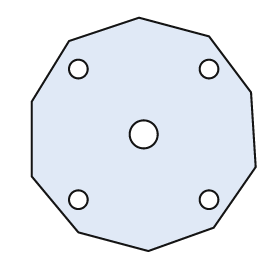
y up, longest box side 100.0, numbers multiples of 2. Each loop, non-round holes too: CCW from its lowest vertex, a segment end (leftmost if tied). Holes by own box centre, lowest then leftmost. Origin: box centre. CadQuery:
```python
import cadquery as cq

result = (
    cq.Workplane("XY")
    .moveTo(2.0, -50.0)
    .lineTo(30.0, -40.0)
    .lineTo(48.0, -14.0)
    .lineTo(46.0, 18.0)
    .lineTo(28.0, 42.0)
    .lineTo(-2.0, 50.0)
    .lineTo(-32.0, 40.0)
    .lineTo(-48.0, 14.0)
    .lineTo(-48.0, -18.0)
    .lineTo(-28.0, -42.0)
    .close()
    .moveTo(-28.0, -28.0)
    .circle(4.0)
    .moveTo(28.0, -28.0)
    .circle(4.0)
    .moveTo(0.0, 0.0)
    .circle(6.0)
    .moveTo(-28.0, 28.0)
    .circle(4.0)
    .moveTo(28.0, 28.0)
    .circle(4.0)
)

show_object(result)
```